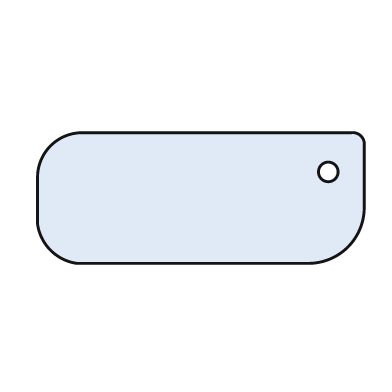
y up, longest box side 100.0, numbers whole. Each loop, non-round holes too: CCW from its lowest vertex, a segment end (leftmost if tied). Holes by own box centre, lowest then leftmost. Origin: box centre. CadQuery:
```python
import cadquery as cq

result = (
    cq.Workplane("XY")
    .moveTo(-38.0, -20.0)
    .lineTo(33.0, -20.0)
    .threePointArc((45.0, -15.0), (50.0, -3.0))
    .lineTo(50.0, 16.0)
    .threePointArc((49.0, 19.0), (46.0, 20.0))
    .lineTo(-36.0, 20.0)
    .threePointArc((-46.0, 16.0), (-50.0, 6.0))
    .lineTo(-50.0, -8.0)
    .threePointArc((-46.0, -16.0), (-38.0, -20.0))
    .close()
    .moveTo(39.0, 8.0)
    .circle(3.0)
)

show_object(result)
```